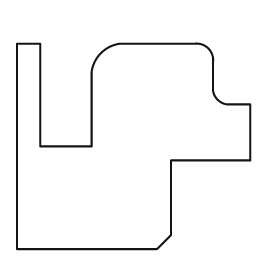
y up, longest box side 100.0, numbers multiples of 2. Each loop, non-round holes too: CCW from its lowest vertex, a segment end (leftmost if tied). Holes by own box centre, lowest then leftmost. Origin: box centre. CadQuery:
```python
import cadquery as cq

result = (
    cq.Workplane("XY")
    .moveTo(-50.0, -44.0)
    .lineTo(10.0, -44.0)
    .lineTo(16.0, -38.0)
    .lineTo(16.0, -6.0)
    .lineTo(50.0, -6.0)
    .lineTo(50.0, 18.0)
    .lineTo(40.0, 18.0)
    .threePointArc((36.0, 20.0), (34.0, 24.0))
    .lineTo(34.0, 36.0)
    .threePointArc((32.0, 42.0), (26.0, 44.0))
    .lineTo(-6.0, 44.0)
    .threePointArc((-14.0, 40.0), (-18.0, 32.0))
    .lineTo(-18.0, 0.0)
    .lineTo(-40.0, 0.0)
    .lineTo(-40.0, 44.0)
    .lineTo(-50.0, 44.0)
    .close()
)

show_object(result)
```